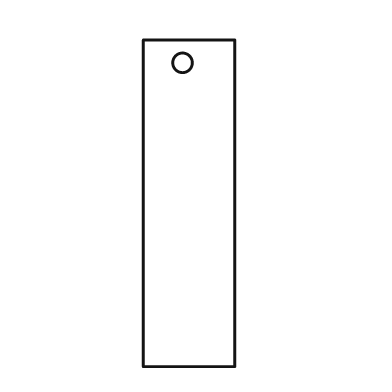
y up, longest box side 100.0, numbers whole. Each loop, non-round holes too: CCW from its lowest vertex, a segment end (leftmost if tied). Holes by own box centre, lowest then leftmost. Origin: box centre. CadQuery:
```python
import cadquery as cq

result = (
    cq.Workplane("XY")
    .moveTo(-14.0, -50.0)
    .lineTo(14.0, -50.0)
    .lineTo(14.0, 50.0)
    .lineTo(-14.0, 50.0)
    .close()
    .moveTo(-2.0, 43.0)
    .circle(3.0)
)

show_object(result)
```